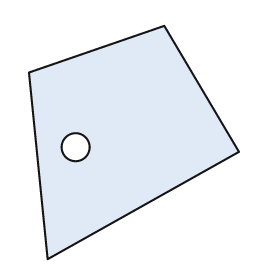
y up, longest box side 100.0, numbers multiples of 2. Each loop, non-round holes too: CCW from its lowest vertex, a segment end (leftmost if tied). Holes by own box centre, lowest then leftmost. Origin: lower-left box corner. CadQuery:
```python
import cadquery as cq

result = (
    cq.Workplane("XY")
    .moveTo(8.0, 0.0)
    .lineTo(90.0, 46.0)
    .lineTo(58.0, 100.0)
    .lineTo(0.0, 80.0)
    .close()
    .moveTo(20.0, 48.0)
    .circle(6.0)
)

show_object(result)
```